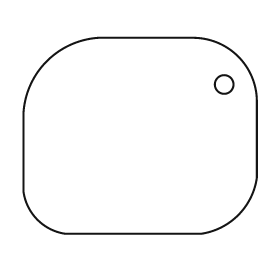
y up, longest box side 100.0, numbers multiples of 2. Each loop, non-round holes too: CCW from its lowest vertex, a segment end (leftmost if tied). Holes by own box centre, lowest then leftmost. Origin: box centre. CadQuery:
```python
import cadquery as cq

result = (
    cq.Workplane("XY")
    .moveTo(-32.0, -42.0)
    .lineTo(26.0, -42.0)
    .threePointArc((42.0, -34.0), (50.0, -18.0))
    .lineTo(50.0, 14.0)
    .threePointArc((42.0, 34.0), (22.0, 42.0))
    .lineTo(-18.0, 42.0)
    .threePointArc((-40.0, 32.0), (-50.0, 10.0))
    .lineTo(-50.0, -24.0)
    .threePointArc((-44.0, -36.0), (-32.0, -42.0))
    .close()
    .moveTo(36.0, 22.0)
    .circle(4.0)
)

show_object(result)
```